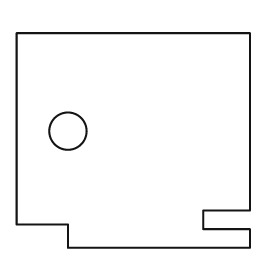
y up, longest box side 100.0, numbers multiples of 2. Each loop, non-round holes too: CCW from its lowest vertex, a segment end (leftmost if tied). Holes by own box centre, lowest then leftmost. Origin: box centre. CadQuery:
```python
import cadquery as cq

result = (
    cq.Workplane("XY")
    .moveTo(-28.0, -46.0)
    .lineTo(50.0, -46.0)
    .lineTo(50.0, -38.0)
    .lineTo(30.0, -38.0)
    .lineTo(30.0, -30.0)
    .lineTo(50.0, -30.0)
    .lineTo(50.0, 46.0)
    .lineTo(-50.0, 46.0)
    .lineTo(-50.0, -36.0)
    .lineTo(-28.0, -36.0)
    .close()
    .moveTo(-28.0, 4.0)
    .circle(8.0)
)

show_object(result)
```